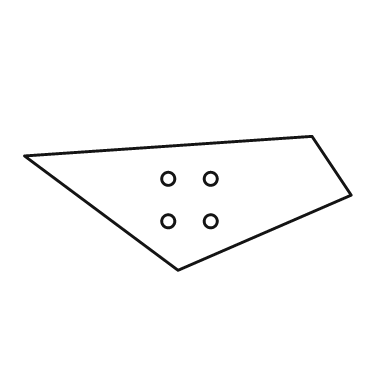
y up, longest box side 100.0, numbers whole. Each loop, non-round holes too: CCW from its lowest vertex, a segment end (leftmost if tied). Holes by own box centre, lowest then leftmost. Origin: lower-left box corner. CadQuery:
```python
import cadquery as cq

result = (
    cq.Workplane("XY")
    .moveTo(47.0, 0.0)
    .lineTo(100.0, 23.0)
    .lineTo(88.0, 41.0)
    .lineTo(0.0, 35.0)
    .close()
    .moveTo(44.0, 15.0)
    .circle(2.0)
    .moveTo(57.0, 15.0)
    .circle(2.0)
    .moveTo(44.0, 28.0)
    .circle(2.0)
    .moveTo(57.0, 28.0)
    .circle(2.0)
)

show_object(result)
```